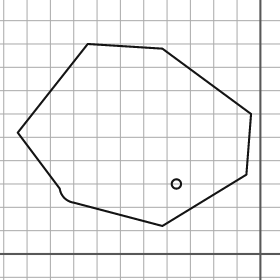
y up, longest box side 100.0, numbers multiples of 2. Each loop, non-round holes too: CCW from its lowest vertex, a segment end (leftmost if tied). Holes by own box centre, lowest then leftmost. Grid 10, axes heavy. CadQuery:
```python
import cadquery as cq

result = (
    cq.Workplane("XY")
    .moveTo(-42.0, 12.0)
    .lineTo(-6.0, 34.0)
    .lineTo(-4.0, 60.0)
    .lineTo(-42.0, 88.0)
    .lineTo(-74.0, 90.0)
    .lineTo(-104.0, 52.0)
    .lineTo(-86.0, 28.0)
    .threePointArc((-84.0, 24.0), (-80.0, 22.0))
    .close()
    .moveTo(-36.0, 30.0)
    .circle(2.0)
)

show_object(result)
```